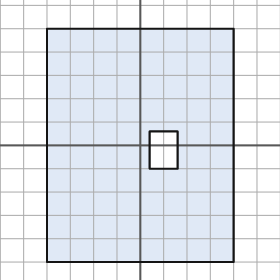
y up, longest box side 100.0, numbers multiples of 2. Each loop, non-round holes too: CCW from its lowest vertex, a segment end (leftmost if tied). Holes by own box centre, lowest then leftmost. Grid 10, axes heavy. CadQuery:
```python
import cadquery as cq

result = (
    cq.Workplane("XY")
    .moveTo(-40.0, -50.0)
    .lineTo(40.0, -50.0)
    .lineTo(40.0, 50.0)
    .lineTo(-40.0, 50.0)
    .close()
    .moveTo(4.0, -10.0)
    .lineTo(16.0, -10.0)
    .lineTo(16.0, 6.0)
    .lineTo(4.0, 6.0)
    .close()
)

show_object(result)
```